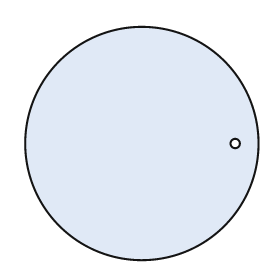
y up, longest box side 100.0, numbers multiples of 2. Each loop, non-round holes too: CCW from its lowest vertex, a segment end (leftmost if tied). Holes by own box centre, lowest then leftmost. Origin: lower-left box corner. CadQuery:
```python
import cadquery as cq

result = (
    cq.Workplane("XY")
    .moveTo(50.0, 50.0)
    .circle(50.0)
    .moveTo(90.0, 50.0)
    .circle(2.0)
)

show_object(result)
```